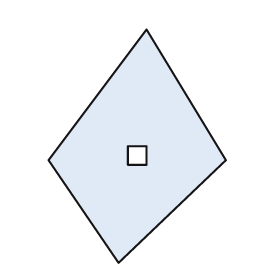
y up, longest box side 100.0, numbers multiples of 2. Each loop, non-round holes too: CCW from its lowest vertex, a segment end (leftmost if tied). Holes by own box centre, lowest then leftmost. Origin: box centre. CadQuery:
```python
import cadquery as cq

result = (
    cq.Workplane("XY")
    .moveTo(-8.0, -50.0)
    .lineTo(38.0, -6.0)
    .lineTo(4.0, 50.0)
    .lineTo(-38.0, -6.0)
    .close()
    .moveTo(-4.0, -8.0)
    .lineTo(4.0, -8.0)
    .lineTo(4.0, 0.0)
    .lineTo(-4.0, 0.0)
    .close()
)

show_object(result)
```